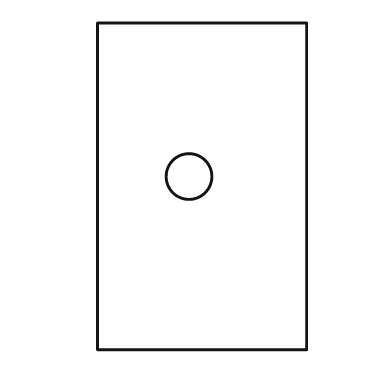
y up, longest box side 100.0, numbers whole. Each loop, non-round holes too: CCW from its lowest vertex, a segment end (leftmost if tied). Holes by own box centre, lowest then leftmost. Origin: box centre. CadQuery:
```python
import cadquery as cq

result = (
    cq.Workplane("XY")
    .moveTo(-32.0, -50.0)
    .lineTo(32.0, -50.0)
    .lineTo(32.0, 50.0)
    .lineTo(-32.0, 50.0)
    .close()
    .moveTo(-4.0, 3.0)
    .circle(7.0)
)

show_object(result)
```